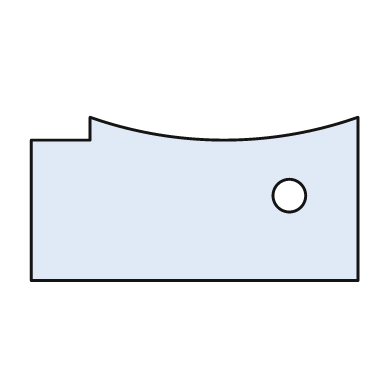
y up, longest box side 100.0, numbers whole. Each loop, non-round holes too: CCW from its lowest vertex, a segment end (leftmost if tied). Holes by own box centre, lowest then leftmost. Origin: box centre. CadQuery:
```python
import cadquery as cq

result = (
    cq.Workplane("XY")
    .moveTo(-50.0, -25.0)
    .lineTo(50.0, -25.0)
    .lineTo(50.0, 25.0)
    .threePointArc((9.0, 18.0), (-32.0, 25.0))
    .lineTo(-32.0, 18.0)
    .lineTo(-50.0, 18.0)
    .close()
    .moveTo(29.0, 1.0)
    .circle(5.0)
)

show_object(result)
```